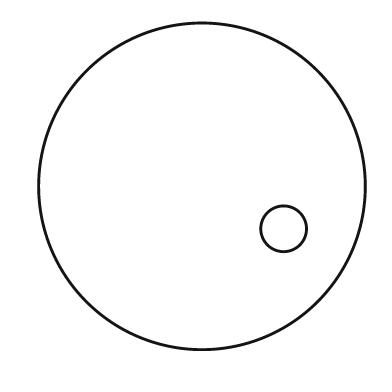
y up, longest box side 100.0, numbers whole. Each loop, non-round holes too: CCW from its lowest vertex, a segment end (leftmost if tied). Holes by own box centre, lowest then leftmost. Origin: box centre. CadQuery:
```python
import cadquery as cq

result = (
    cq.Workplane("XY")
    .moveTo(0.0, 0.0)
    .circle(50.0)
    .moveTo(25.0, -13.0)
    .circle(7.0)
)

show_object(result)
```